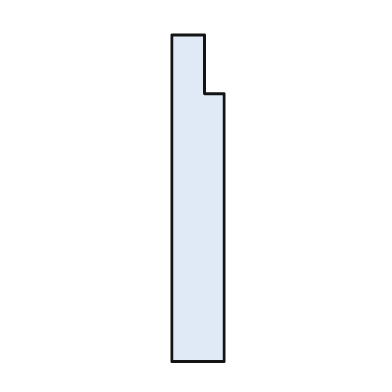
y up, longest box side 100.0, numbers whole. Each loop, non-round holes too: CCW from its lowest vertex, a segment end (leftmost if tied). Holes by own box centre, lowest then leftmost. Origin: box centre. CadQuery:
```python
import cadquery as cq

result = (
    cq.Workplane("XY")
    .moveTo(-8.0, -50.0)
    .lineTo(8.0, -50.0)
    .lineTo(8.0, 32.0)
    .lineTo(2.0, 32.0)
    .lineTo(2.0, 50.0)
    .lineTo(-8.0, 50.0)
    .close()
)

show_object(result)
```